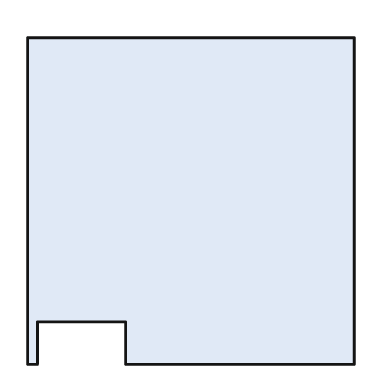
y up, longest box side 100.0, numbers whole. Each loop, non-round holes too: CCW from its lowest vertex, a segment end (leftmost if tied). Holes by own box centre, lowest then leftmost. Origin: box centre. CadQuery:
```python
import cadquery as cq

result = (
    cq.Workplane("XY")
    .moveTo(-50.0, -50.0)
    .lineTo(-47.0, -50.0)
    .lineTo(-47.0, -37.0)
    .lineTo(-20.0, -37.0)
    .lineTo(-20.0, -50.0)
    .lineTo(50.0, -50.0)
    .lineTo(50.0, 50.0)
    .lineTo(-50.0, 50.0)
    .close()
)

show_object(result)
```